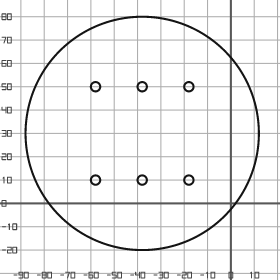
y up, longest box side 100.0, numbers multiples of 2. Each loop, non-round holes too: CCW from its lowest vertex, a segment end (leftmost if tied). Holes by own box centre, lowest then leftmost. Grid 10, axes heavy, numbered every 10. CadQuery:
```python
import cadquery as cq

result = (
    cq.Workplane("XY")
    .moveTo(-38.0, 30.0)
    .circle(50.0)
    .moveTo(-58.0, 10.0)
    .circle(2.0)
    .moveTo(-38.0, 10.0)
    .circle(2.0)
    .moveTo(-18.0, 10.0)
    .circle(2.0)
    .moveTo(-58.0, 50.0)
    .circle(2.0)
    .moveTo(-38.0, 50.0)
    .circle(2.0)
    .moveTo(-18.0, 50.0)
    .circle(2.0)
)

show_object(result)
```